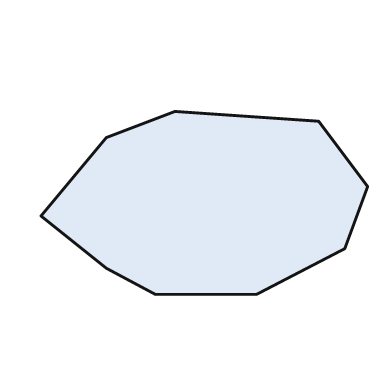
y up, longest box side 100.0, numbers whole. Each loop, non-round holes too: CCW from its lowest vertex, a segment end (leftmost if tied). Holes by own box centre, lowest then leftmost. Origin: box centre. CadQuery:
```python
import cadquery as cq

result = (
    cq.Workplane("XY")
    .moveTo(-15.0, -28.0)
    .lineTo(16.0, -28.0)
    .lineTo(43.0, -14.0)
    .lineTo(50.0, 5.0)
    .lineTo(35.0, 25.0)
    .lineTo(-9.0, 28.0)
    .lineTo(-30.0, 20.0)
    .lineTo(-50.0, -4.0)
    .lineTo(-30.0, -20.0)
    .close()
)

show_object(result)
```